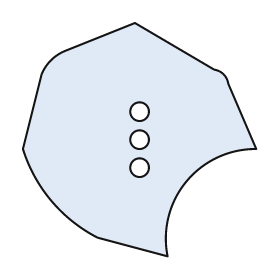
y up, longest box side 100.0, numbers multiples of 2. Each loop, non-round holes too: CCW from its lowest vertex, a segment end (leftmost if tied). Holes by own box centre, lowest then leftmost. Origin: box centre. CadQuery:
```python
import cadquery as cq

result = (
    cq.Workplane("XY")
    .moveTo(12.0, -50.0)
    .threePointArc((20.0, -18.0), (50.0, -4.0))
    .lineTo(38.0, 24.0)
    .threePointArc((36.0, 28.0), (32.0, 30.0))
    .lineTo(-2.0, 50.0)
    .lineTo(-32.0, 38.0)
    .threePointArc((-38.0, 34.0), (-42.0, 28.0))
    .lineTo(-50.0, -4.0)
    .threePointArc((-38.0, -26.0), (-18.0, -42.0))
    .close()
    .moveTo(0.0, -12.0)
    .circle(4.0)
    .moveTo(0.0, 0.0)
    .circle(4.0)
    .moveTo(0.0, 12.0)
    .circle(4.0)
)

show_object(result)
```